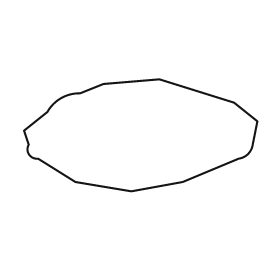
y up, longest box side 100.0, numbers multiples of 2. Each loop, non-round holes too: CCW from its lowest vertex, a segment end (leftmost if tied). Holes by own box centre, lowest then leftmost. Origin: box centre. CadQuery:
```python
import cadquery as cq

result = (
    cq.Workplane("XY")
    .moveTo(-4.0, -24.0)
    .lineTo(18.0, -20.0)
    .lineTo(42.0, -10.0)
    .threePointArc((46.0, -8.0), (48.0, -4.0))
    .lineTo(50.0, 6.0)
    .lineTo(40.0, 14.0)
    .lineTo(8.0, 24.0)
    .lineTo(-16.0, 22.0)
    .lineTo(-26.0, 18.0)
    .threePointArc((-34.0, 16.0), (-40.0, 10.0))
    .lineTo(-50.0, 2.0)
    .lineTo(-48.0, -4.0)
    .threePointArc((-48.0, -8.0), (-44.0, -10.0))
    .lineTo(-28.0, -20.0)
    .close()
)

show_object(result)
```